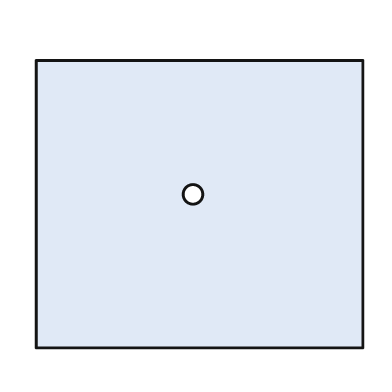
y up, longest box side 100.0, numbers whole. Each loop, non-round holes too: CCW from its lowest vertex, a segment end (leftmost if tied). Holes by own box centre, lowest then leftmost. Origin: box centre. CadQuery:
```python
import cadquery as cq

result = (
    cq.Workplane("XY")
    .moveTo(-50.0, -44.0)
    .lineTo(50.0, -44.0)
    .lineTo(50.0, 44.0)
    .lineTo(-50.0, 44.0)
    .close()
    .moveTo(-2.0, 3.0)
    .circle(3.0)
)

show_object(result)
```